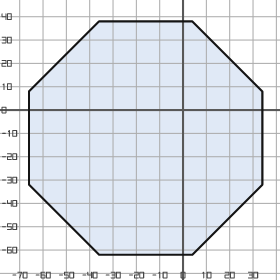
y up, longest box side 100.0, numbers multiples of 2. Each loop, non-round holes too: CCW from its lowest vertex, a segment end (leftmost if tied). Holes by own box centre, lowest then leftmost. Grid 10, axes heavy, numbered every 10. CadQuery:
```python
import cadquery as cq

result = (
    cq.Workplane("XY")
    .moveTo(-36.0, -62.0)
    .lineTo(4.0, -62.0)
    .lineTo(34.0, -32.0)
    .lineTo(34.0, 8.0)
    .lineTo(4.0, 38.0)
    .lineTo(-36.0, 38.0)
    .lineTo(-66.0, 8.0)
    .lineTo(-66.0, -32.0)
    .close()
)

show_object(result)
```